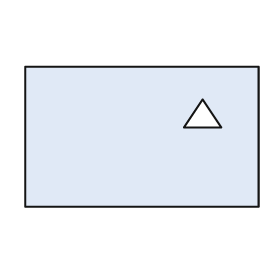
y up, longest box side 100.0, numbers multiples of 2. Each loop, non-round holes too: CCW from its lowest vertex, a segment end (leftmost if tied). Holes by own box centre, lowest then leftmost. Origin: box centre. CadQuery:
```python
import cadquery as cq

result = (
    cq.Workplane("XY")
    .moveTo(-50.0, -30.0)
    .lineTo(50.0, -30.0)
    .lineTo(50.0, 30.0)
    .lineTo(-50.0, 30.0)
    .close()
    .moveTo(18.0, 4.0)
    .lineTo(34.0, 4.0)
    .lineTo(26.0, 16.0)
    .close()
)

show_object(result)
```